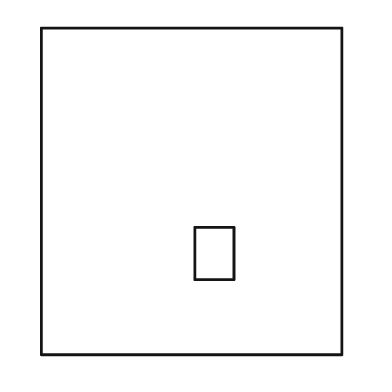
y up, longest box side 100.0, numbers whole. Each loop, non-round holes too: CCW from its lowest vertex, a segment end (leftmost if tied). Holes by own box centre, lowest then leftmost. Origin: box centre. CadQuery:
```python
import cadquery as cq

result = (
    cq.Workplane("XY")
    .moveTo(-46.0, -50.0)
    .lineTo(46.0, -50.0)
    .lineTo(46.0, 50.0)
    .lineTo(-46.0, 50.0)
    .close()
    .moveTo(1.0, -27.0)
    .lineTo(13.0, -27.0)
    .lineTo(13.0, -11.0)
    .lineTo(1.0, -11.0)
    .close()
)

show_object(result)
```